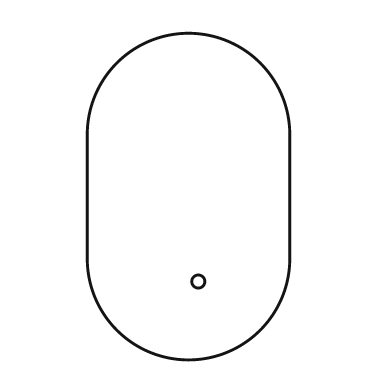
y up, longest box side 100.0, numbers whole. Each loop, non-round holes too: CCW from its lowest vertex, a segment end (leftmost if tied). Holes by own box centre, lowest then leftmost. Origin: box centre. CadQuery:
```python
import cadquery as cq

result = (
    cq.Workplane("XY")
    .moveTo(-31.0, -19.0)
    .threePointArc((0.0, -50.0), (31.0, -19.0))
    .lineTo(31.0, 19.0)
    .threePointArc((0.0, 50.0), (-31.0, 19.0))
    .close()
    .moveTo(3.0, -26.0)
    .circle(2.0)
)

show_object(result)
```